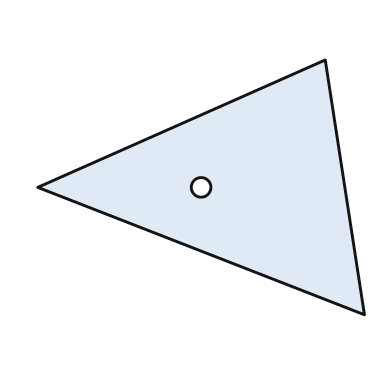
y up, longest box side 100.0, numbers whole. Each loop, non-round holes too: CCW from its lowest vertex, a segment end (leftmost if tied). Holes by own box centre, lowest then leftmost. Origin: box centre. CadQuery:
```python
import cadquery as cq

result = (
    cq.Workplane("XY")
    .moveTo(50.0, -39.0)
    .lineTo(38.0, 39.0)
    .lineTo(-50.0, 0.0)
    .close()
    .moveTo(0.0, 0.0)
    .circle(3.0)
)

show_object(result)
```